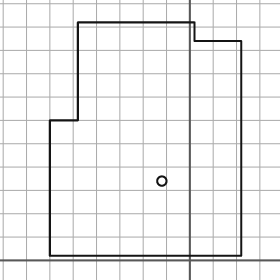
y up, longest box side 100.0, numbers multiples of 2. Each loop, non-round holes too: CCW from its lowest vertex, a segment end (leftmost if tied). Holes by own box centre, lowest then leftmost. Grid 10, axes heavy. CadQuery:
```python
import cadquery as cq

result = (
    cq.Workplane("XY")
    .moveTo(-60.0, 2.0)
    .lineTo(22.0, 2.0)
    .lineTo(22.0, 94.0)
    .lineTo(2.0, 94.0)
    .lineTo(2.0, 102.0)
    .lineTo(-48.0, 102.0)
    .lineTo(-48.0, 60.0)
    .lineTo(-60.0, 60.0)
    .close()
    .moveTo(-12.0, 34.0)
    .circle(2.0)
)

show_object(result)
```